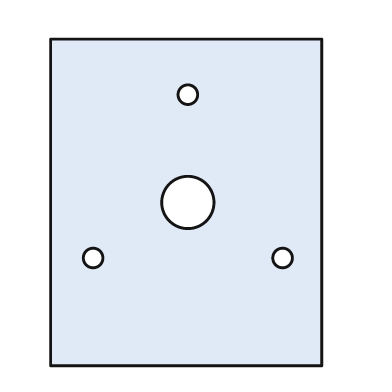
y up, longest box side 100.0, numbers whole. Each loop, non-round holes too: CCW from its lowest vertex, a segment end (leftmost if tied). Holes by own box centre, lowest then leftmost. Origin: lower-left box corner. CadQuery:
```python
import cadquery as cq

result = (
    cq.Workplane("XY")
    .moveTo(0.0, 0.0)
    .lineTo(83.0, 0.0)
    .lineTo(83.0, 100.0)
    .lineTo(0.0, 100.0)
    .close()
    .moveTo(13.0, 33.0)
    .circle(3.0)
    .moveTo(71.0, 33.0)
    .circle(3.0)
    .moveTo(42.0, 50.0)
    .circle(8.0)
    .moveTo(42.0, 83.0)
    .circle(3.0)
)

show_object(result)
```